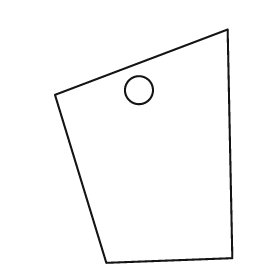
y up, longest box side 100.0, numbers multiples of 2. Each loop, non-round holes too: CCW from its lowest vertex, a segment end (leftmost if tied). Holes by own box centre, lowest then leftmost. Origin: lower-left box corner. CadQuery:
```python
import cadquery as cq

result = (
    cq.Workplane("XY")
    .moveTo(22.0, 0.0)
    .lineTo(76.0, 2.0)
    .lineTo(74.0, 100.0)
    .lineTo(0.0, 72.0)
    .close()
    .moveTo(36.0, 74.0)
    .circle(6.0)
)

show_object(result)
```